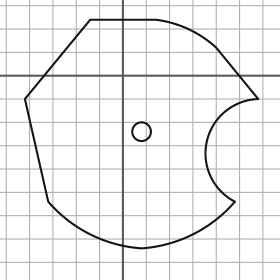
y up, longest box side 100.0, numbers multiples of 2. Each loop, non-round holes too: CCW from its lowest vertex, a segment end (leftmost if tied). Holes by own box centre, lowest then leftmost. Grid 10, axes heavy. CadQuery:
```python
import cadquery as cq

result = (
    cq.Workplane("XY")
    .moveTo(8.0, -74.0)
    .threePointArc((30.0, -68.0), (48.0, -54.0))
    .threePointArc((36.0, -28.0), (58.0, -10.0))
    .lineTo(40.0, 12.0)
    .threePointArc((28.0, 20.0), (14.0, 24.0))
    .lineTo(-14.0, 24.0)
    .lineTo(-42.0, -10.0)
    .lineTo(-32.0, -54.0)
    .threePointArc((-14.0, -68.0), (8.0, -74.0))
    .close()
    .moveTo(8.0, -24.0)
    .circle(4.0)
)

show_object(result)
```